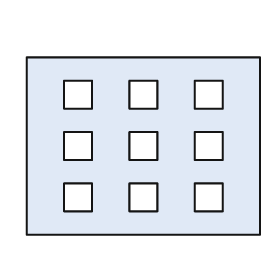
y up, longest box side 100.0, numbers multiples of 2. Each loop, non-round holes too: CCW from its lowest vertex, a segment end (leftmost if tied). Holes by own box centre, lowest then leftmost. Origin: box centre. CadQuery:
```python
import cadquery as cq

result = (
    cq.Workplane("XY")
    .moveTo(-50.0, -38.0)
    .lineTo(50.0, -38.0)
    .lineTo(50.0, 38.0)
    .lineTo(-50.0, 38.0)
    .close()
    .moveTo(-34.0, -28.0)
    .lineTo(-22.0, -28.0)
    .lineTo(-22.0, -16.0)
    .lineTo(-34.0, -16.0)
    .close()
    .moveTo(-6.0, -28.0)
    .lineTo(6.0, -28.0)
    .lineTo(6.0, -16.0)
    .lineTo(-6.0, -16.0)
    .close()
    .moveTo(22.0, -28.0)
    .lineTo(34.0, -28.0)
    .lineTo(34.0, -16.0)
    .lineTo(22.0, -16.0)
    .close()
    .moveTo(-34.0, -6.0)
    .lineTo(-22.0, -6.0)
    .lineTo(-22.0, 6.0)
    .lineTo(-34.0, 6.0)
    .close()
    .moveTo(-6.0, -6.0)
    .lineTo(6.0, -6.0)
    .lineTo(6.0, 6.0)
    .lineTo(-6.0, 6.0)
    .close()
    .moveTo(22.0, -6.0)
    .lineTo(34.0, -6.0)
    .lineTo(34.0, 6.0)
    .lineTo(22.0, 6.0)
    .close()
    .moveTo(-34.0, 16.0)
    .lineTo(-22.0, 16.0)
    .lineTo(-22.0, 28.0)
    .lineTo(-34.0, 28.0)
    .close()
    .moveTo(-6.0, 16.0)
    .lineTo(6.0, 16.0)
    .lineTo(6.0, 28.0)
    .lineTo(-6.0, 28.0)
    .close()
    .moveTo(22.0, 16.0)
    .lineTo(34.0, 16.0)
    .lineTo(34.0, 28.0)
    .lineTo(22.0, 28.0)
    .close()
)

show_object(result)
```